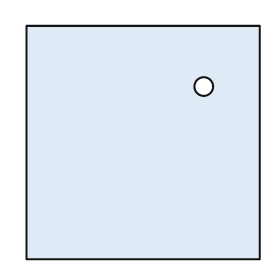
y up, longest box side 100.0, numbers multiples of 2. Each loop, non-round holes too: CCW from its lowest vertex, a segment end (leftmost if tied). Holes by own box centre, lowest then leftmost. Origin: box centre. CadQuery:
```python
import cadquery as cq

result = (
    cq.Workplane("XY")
    .moveTo(-50.0, -50.0)
    .lineTo(50.0, -50.0)
    .lineTo(50.0, 50.0)
    .lineTo(-50.0, 50.0)
    .close()
    .moveTo(26.0, 24.0)
    .circle(4.0)
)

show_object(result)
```